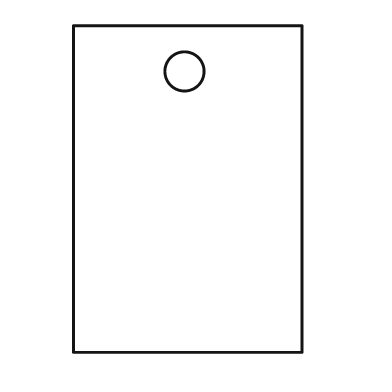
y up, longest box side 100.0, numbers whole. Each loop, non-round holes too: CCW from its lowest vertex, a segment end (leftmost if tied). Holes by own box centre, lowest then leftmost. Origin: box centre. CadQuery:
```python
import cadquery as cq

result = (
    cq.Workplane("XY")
    .moveTo(-35.0, -50.0)
    .lineTo(35.0, -50.0)
    .lineTo(35.0, 50.0)
    .lineTo(-35.0, 50.0)
    .close()
    .moveTo(-1.0, 36.0)
    .circle(6.0)
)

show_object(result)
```